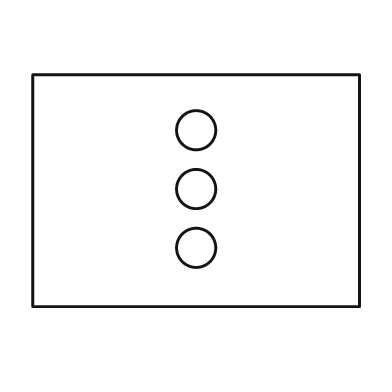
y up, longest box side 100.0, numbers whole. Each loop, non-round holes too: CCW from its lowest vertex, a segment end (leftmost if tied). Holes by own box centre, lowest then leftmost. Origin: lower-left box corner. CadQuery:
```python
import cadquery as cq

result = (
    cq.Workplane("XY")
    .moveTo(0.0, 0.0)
    .lineTo(100.0, 0.0)
    .lineTo(100.0, 71.0)
    .lineTo(0.0, 71.0)
    .close()
    .moveTo(50.0, 18.0)
    .circle(6.0)
    .moveTo(50.0, 36.0)
    .circle(6.0)
    .moveTo(50.0, 54.0)
    .circle(6.0)
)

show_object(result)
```